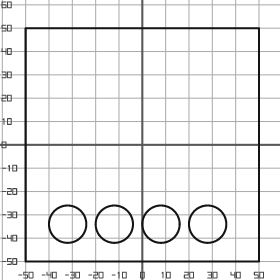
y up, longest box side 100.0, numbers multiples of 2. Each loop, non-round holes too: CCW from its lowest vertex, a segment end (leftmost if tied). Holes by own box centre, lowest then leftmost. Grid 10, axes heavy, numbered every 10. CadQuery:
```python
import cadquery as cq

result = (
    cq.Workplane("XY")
    .moveTo(-50.0, -50.0)
    .lineTo(50.0, -50.0)
    .lineTo(50.0, 50.0)
    .lineTo(-50.0, 50.0)
    .close()
    .moveTo(-32.0, -34.0)
    .circle(8.0)
    .moveTo(-12.0, -34.0)
    .circle(8.0)
    .moveTo(8.0, -34.0)
    .circle(8.0)
    .moveTo(28.0, -34.0)
    .circle(8.0)
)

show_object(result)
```